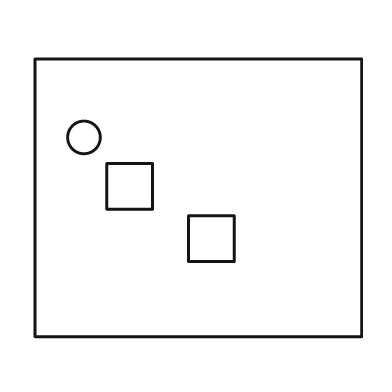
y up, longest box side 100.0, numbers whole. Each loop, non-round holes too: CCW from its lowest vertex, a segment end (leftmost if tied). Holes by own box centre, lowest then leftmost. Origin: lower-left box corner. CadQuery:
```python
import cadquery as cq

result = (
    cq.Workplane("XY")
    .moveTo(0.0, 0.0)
    .lineTo(100.0, 0.0)
    .lineTo(100.0, 85.0)
    .lineTo(0.0, 85.0)
    .close()
    .moveTo(47.0, 23.0)
    .lineTo(61.0, 23.0)
    .lineTo(61.0, 37.0)
    .lineTo(47.0, 37.0)
    .close()
    .moveTo(22.0, 39.0)
    .lineTo(36.0, 39.0)
    .lineTo(36.0, 53.0)
    .lineTo(22.0, 53.0)
    .close()
    .moveTo(15.0, 61.0)
    .circle(5.0)
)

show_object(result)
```